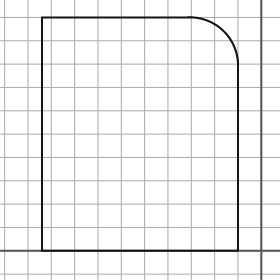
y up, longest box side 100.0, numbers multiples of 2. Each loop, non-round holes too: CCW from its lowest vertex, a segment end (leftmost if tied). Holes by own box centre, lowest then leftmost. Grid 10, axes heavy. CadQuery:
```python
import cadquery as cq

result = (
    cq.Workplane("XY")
    .moveTo(-94.0, 0.0)
    .lineTo(-10.0, 0.0)
    .lineTo(-10.0, 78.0)
    .threePointArc((-16.0, 94.0), (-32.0, 100.0))
    .lineTo(-94.0, 100.0)
    .close()
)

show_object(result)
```